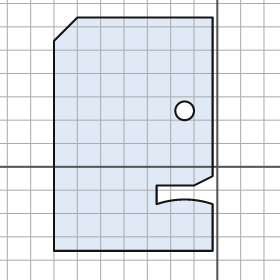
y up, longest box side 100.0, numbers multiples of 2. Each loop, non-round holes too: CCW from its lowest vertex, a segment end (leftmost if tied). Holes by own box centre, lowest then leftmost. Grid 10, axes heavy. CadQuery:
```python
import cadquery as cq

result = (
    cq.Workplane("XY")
    .moveTo(-70.0, -36.0)
    .lineTo(-2.0, -36.0)
    .lineTo(-2.0, -16.0)
    .threePointArc((-14.0, -14.0), (-26.0, -16.0))
    .lineTo(-26.0, -8.0)
    .lineTo(-10.0, -8.0)
    .lineTo(-2.0, -4.0)
    .lineTo(-2.0, 64.0)
    .lineTo(-60.0, 64.0)
    .lineTo(-70.0, 54.0)
    .close()
    .moveTo(-14.0, 24.0)
    .circle(4.0)
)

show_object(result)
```